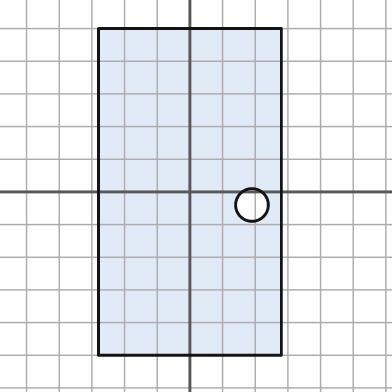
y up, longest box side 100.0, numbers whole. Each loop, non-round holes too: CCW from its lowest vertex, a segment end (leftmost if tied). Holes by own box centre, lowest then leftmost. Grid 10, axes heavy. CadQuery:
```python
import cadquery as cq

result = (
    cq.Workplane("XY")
    .moveTo(-28.0, -50.0)
    .lineTo(28.0, -50.0)
    .lineTo(28.0, 50.0)
    .lineTo(-28.0, 50.0)
    .close()
    .moveTo(19.0, -4.0)
    .circle(5.0)
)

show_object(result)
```